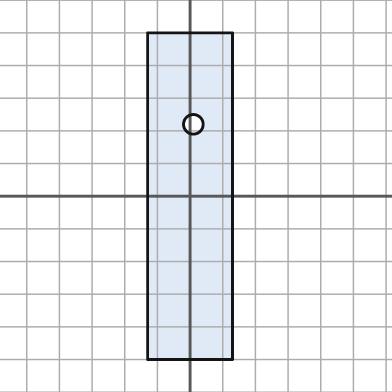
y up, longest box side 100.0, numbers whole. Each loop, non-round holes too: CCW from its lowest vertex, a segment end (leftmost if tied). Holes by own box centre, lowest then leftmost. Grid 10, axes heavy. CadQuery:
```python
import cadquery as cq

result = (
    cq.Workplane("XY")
    .moveTo(-13.0, -50.0)
    .lineTo(13.0, -50.0)
    .lineTo(13.0, 50.0)
    .lineTo(-13.0, 50.0)
    .close()
    .moveTo(1.0, 22.0)
    .circle(3.0)
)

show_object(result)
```